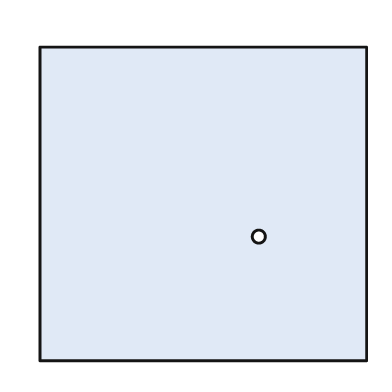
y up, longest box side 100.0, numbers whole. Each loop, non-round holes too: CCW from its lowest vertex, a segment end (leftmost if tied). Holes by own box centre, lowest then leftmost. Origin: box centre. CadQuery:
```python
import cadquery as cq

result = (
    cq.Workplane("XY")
    .moveTo(-50.0, -48.0)
    .lineTo(50.0, -48.0)
    .lineTo(50.0, 48.0)
    .lineTo(-50.0, 48.0)
    .close()
    .moveTo(17.0, -10.0)
    .circle(2.0)
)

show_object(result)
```